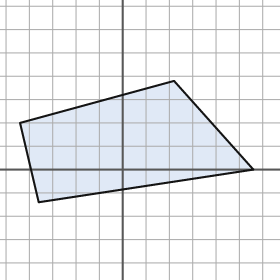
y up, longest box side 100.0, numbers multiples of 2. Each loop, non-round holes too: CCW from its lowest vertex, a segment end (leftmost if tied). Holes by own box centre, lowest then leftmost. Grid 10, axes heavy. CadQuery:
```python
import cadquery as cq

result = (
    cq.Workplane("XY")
    .moveTo(-36.0, -14.0)
    .lineTo(56.0, 0.0)
    .lineTo(22.0, 38.0)
    .lineTo(-44.0, 20.0)
    .close()
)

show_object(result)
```